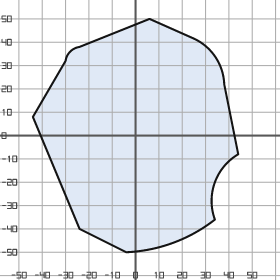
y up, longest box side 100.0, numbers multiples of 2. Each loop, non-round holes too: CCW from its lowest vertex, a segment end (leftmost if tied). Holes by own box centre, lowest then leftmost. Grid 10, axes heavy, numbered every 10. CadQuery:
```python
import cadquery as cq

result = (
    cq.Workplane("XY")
    .moveTo(-4.0, -50.0)
    .threePointArc((16.0, -46.0), (34.0, -36.0))
    .threePointArc((34.0, -20.0), (44.0, -8.0))
    .lineTo(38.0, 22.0)
    .threePointArc((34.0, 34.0), (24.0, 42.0))
    .lineTo(6.0, 50.0)
    .lineTo(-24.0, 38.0)
    .threePointArc((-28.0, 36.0), (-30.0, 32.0))
    .lineTo(-44.0, 8.0)
    .lineTo(-24.0, -40.0)
    .close()
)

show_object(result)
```